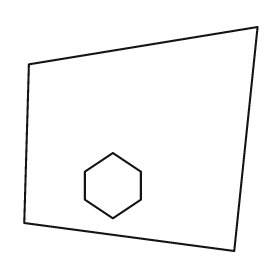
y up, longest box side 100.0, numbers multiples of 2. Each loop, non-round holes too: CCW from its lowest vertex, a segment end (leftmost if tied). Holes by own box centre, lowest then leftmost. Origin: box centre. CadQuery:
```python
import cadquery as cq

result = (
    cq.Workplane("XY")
    .moveTo(40.0, -48.0)
    .lineTo(50.0, 48.0)
    .lineTo(-48.0, 32.0)
    .lineTo(-50.0, -36.0)
    .close()
    .moveTo(-12.0, -34.0)
    .lineTo(0.0, -26.0)
    .lineTo(0.0, -14.0)
    .lineTo(-12.0, -6.0)
    .lineTo(-24.0, -14.0)
    .lineTo(-24.0, -26.0)
    .close()
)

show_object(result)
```